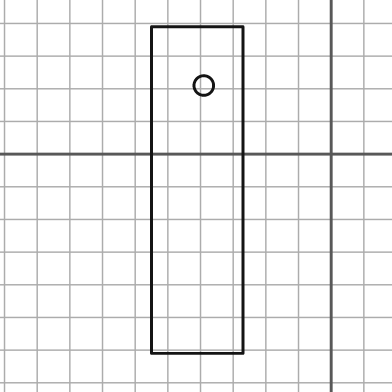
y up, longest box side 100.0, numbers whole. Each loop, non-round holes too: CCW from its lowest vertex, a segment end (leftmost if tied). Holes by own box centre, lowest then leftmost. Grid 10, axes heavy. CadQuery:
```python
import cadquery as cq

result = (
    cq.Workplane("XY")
    .moveTo(-55.0, -61.0)
    .lineTo(-27.0, -61.0)
    .lineTo(-27.0, 39.0)
    .lineTo(-55.0, 39.0)
    .close()
    .moveTo(-39.0, 21.0)
    .circle(3.0)
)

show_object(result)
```